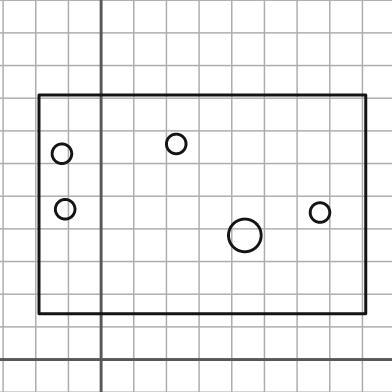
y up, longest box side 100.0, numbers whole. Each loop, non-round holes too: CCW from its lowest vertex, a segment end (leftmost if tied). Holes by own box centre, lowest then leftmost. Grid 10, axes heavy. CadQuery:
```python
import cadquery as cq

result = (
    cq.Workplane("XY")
    .moveTo(-19.0, 14.0)
    .lineTo(81.0, 14.0)
    .lineTo(81.0, 81.0)
    .lineTo(-19.0, 81.0)
    .close()
    .moveTo(44.0, 38.0)
    .circle(5.0)
    .moveTo(67.0, 45.0)
    .circle(3.0)
    .moveTo(-11.0, 46.0)
    .circle(3.0)
    .moveTo(-12.0, 63.0)
    .circle(3.0)
    .moveTo(23.0, 66.0)
    .circle(3.0)
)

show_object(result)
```